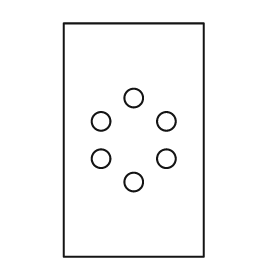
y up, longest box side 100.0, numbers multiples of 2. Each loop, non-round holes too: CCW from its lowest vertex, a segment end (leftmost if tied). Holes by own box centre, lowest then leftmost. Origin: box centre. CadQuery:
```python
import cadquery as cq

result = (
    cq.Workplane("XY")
    .moveTo(-30.0, -50.0)
    .lineTo(30.0, -50.0)
    .lineTo(30.0, 50.0)
    .lineTo(-30.0, 50.0)
    .close()
    .moveTo(0.0, -18.0)
    .circle(4.0)
    .moveTo(-14.0, -8.0)
    .circle(4.0)
    .moveTo(14.0, -8.0)
    .circle(4.0)
    .moveTo(-14.0, 8.0)
    .circle(4.0)
    .moveTo(14.0, 8.0)
    .circle(4.0)
    .moveTo(0.0, 18.0)
    .circle(4.0)
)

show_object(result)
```